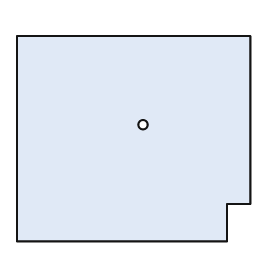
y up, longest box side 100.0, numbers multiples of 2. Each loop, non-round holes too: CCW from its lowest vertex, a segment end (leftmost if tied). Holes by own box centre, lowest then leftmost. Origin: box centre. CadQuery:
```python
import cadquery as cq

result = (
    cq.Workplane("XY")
    .moveTo(-50.0, -44.0)
    .lineTo(40.0, -44.0)
    .lineTo(40.0, -28.0)
    .lineTo(50.0, -28.0)
    .lineTo(50.0, 44.0)
    .lineTo(-50.0, 44.0)
    .close()
    .moveTo(4.0, 6.0)
    .circle(2.0)
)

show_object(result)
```